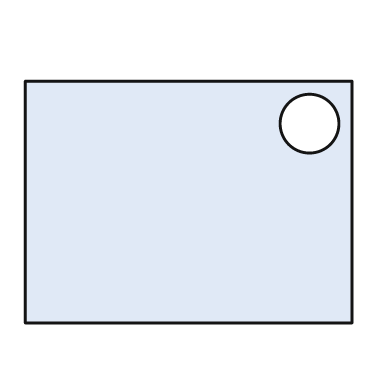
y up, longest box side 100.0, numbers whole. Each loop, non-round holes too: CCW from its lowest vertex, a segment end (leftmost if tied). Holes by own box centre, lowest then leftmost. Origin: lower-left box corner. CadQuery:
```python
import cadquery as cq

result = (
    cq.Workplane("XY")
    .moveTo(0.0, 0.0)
    .lineTo(100.0, 0.0)
    .lineTo(100.0, 74.0)
    .lineTo(0.0, 74.0)
    .close()
    .moveTo(87.0, 61.0)
    .circle(9.0)
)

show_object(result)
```